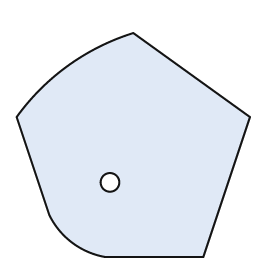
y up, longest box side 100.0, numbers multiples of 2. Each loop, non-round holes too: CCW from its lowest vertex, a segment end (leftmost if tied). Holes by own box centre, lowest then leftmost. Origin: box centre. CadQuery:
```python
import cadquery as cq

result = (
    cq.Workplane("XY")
    .moveTo(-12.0, -48.0)
    .lineTo(30.0, -48.0)
    .lineTo(50.0, 12.0)
    .lineTo(0.0, 48.0)
    .threePointArc((-28.0, 34.0), (-50.0, 12.0))
    .lineTo(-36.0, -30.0)
    .threePointArc((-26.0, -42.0), (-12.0, -48.0))
    .close()
    .moveTo(-10.0, -16.0)
    .circle(4.0)
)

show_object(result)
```